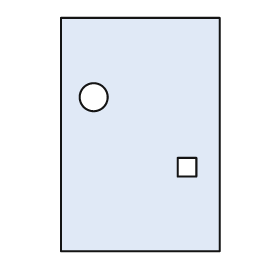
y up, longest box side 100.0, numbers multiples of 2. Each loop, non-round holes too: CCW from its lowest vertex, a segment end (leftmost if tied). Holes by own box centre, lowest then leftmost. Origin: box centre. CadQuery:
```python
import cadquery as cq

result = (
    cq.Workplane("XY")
    .moveTo(-34.0, -50.0)
    .lineTo(34.0, -50.0)
    .lineTo(34.0, 50.0)
    .lineTo(-34.0, 50.0)
    .close()
    .moveTo(16.0, -18.0)
    .lineTo(24.0, -18.0)
    .lineTo(24.0, -10.0)
    .lineTo(16.0, -10.0)
    .close()
    .moveTo(-20.0, 16.0)
    .circle(6.0)
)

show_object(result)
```